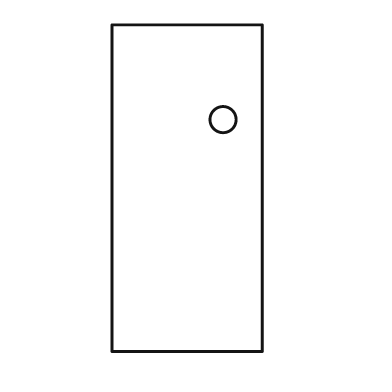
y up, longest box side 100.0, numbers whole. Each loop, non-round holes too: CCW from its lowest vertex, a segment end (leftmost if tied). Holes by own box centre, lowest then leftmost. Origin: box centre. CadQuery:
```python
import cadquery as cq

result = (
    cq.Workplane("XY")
    .moveTo(-23.0, -50.0)
    .lineTo(23.0, -50.0)
    .lineTo(23.0, 50.0)
    .lineTo(-23.0, 50.0)
    .close()
    .moveTo(11.0, 21.0)
    .circle(4.0)
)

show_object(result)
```